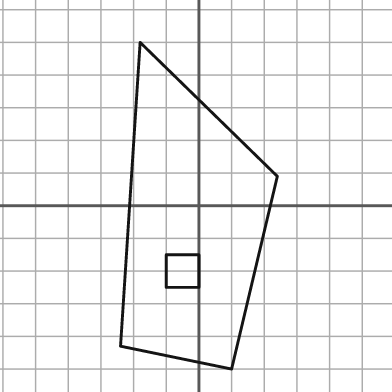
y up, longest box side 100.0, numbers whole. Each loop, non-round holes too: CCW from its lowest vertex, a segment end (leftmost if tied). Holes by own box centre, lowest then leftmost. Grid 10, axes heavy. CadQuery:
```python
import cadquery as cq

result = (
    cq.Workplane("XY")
    .moveTo(10.0, -50.0)
    .lineTo(24.0, 9.0)
    .lineTo(-18.0, 50.0)
    .lineTo(-24.0, -43.0)
    .close()
    .moveTo(-10.0, -25.0)
    .lineTo(0.0, -25.0)
    .lineTo(0.0, -15.0)
    .lineTo(-10.0, -15.0)
    .close()
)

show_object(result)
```